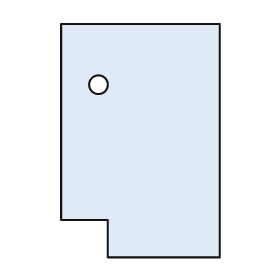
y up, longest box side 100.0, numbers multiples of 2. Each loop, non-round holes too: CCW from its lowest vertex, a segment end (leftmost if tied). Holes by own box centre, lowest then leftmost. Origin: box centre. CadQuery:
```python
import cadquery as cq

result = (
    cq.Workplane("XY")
    .moveTo(-14.0, -50.0)
    .lineTo(34.0, -50.0)
    .lineTo(34.0, 50.0)
    .lineTo(-34.0, 50.0)
    .lineTo(-34.0, -34.0)
    .lineTo(-14.0, -34.0)
    .close()
    .moveTo(-18.0, 24.0)
    .circle(4.0)
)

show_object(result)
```